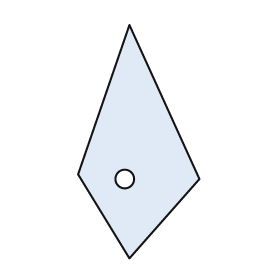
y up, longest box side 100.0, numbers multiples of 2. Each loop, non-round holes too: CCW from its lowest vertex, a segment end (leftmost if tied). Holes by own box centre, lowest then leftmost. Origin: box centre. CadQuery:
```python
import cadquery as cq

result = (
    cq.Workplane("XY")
    .moveTo(-4.0, -50.0)
    .lineTo(26.0, -16.0)
    .lineTo(-4.0, 50.0)
    .lineTo(-26.0, -14.0)
    .close()
    .moveTo(-6.0, -16.0)
    .circle(4.0)
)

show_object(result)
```